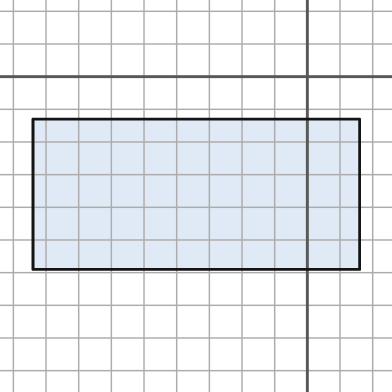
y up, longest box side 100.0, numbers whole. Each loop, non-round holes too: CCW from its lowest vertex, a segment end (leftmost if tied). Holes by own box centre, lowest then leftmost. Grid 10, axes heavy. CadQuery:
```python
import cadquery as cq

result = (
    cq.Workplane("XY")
    .moveTo(-84.0, -59.0)
    .lineTo(16.0, -59.0)
    .lineTo(16.0, -13.0)
    .lineTo(-84.0, -13.0)
    .close()
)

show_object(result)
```